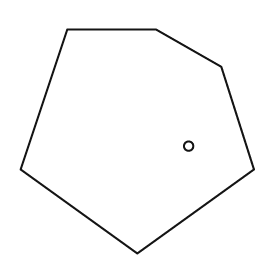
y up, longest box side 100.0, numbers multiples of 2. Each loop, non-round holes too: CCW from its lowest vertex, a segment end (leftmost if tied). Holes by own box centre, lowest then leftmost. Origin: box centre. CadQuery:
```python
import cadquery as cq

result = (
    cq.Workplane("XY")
    .moveTo(0.0, -48.0)
    .lineTo(50.0, -12.0)
    .lineTo(36.0, 32.0)
    .lineTo(8.0, 48.0)
    .lineTo(-30.0, 48.0)
    .lineTo(-50.0, -12.0)
    .close()
    .moveTo(22.0, -2.0)
    .circle(2.0)
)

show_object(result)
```